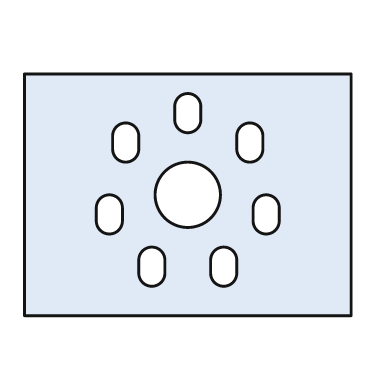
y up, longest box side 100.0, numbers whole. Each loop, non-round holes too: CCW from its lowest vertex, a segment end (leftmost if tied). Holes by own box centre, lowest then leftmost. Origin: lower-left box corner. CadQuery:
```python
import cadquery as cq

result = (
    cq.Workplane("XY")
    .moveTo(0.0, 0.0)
    .lineTo(100.0, 0.0)
    .lineTo(100.0, 74.0)
    .lineTo(0.0, 74.0)
    .close()
    .moveTo(35.0, 13.0)
    .threePointArc((39.0, 9.0), (43.0, 13.0))
    .lineTo(43.0, 17.0)
    .threePointArc((39.0, 21.0), (35.0, 17.0))
    .close()
    .moveTo(57.0, 13.0)
    .threePointArc((61.0, 9.0), (65.0, 13.0))
    .lineTo(65.0, 17.0)
    .threePointArc((61.0, 21.0), (57.0, 17.0))
    .close()
    .moveTo(22.0, 29.0)
    .threePointArc((26.0, 25.0), (30.0, 29.0))
    .lineTo(30.0, 33.0)
    .threePointArc((26.0, 37.0), (22.0, 33.0))
    .close()
    .moveTo(70.0, 29.0)
    .threePointArc((74.0, 25.0), (78.0, 29.0))
    .lineTo(78.0, 33.0)
    .threePointArc((74.0, 37.0), (70.0, 33.0))
    .close()
    .moveTo(50.0, 37.0)
    .circle(10.0)
    .moveTo(27.0, 51.0)
    .threePointArc((31.0, 47.0), (35.0, 51.0))
    .lineTo(35.0, 55.0)
    .threePointArc((31.0, 59.0), (27.0, 55.0))
    .close()
    .moveTo(65.0, 51.0)
    .threePointArc((69.0, 47.0), (73.0, 51.0))
    .lineTo(73.0, 55.0)
    .threePointArc((69.0, 59.0), (65.0, 55.0))
    .close()
    .moveTo(46.0, 60.0)
    .threePointArc((50.0, 56.0), (54.0, 60.0))
    .lineTo(54.0, 64.0)
    .threePointArc((50.0, 68.0), (46.0, 64.0))
    .close()
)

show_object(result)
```